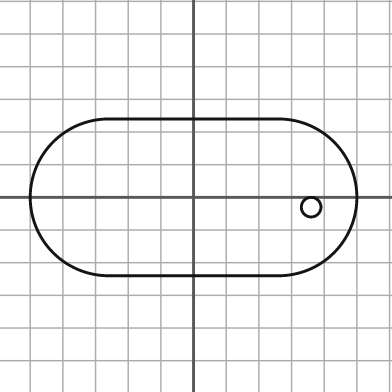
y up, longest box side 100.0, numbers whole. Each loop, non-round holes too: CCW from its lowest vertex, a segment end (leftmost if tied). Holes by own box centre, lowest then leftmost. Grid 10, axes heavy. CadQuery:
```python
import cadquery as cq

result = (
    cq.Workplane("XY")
    .moveTo(-26.0, -24.0)
    .lineTo(26.0, -24.0)
    .threePointArc((50.0, 0.0), (26.0, 24.0))
    .lineTo(-26.0, 24.0)
    .threePointArc((-50.0, 0.0), (-26.0, -24.0))
    .close()
    .moveTo(36.0, -3.0)
    .circle(3.0)
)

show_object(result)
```